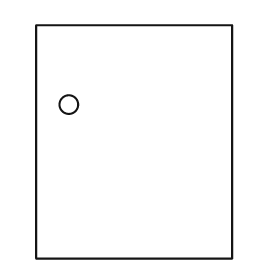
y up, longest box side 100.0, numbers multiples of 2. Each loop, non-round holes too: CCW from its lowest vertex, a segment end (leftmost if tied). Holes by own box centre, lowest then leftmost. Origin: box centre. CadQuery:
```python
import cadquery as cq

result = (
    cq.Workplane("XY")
    .moveTo(-42.0, -50.0)
    .lineTo(42.0, -50.0)
    .lineTo(42.0, 50.0)
    .lineTo(-42.0, 50.0)
    .close()
    .moveTo(-28.0, 16.0)
    .circle(4.0)
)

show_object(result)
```